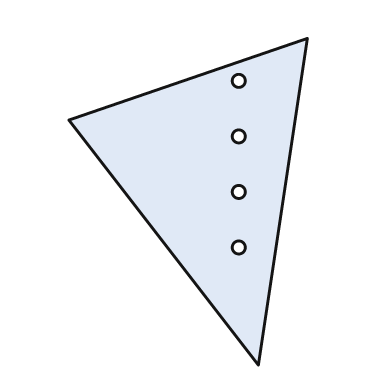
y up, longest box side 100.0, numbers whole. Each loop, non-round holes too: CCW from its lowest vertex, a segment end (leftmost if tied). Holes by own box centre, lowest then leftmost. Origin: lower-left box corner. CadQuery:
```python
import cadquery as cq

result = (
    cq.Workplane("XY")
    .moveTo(58.0, 0.0)
    .lineTo(73.0, 100.0)
    .lineTo(0.0, 75.0)
    .close()
    .moveTo(52.0, 36.0)
    .circle(2.0)
    .moveTo(52.0, 53.0)
    .circle(2.0)
    .moveTo(52.0, 70.0)
    .circle(2.0)
    .moveTo(52.0, 87.0)
    .circle(2.0)
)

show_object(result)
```